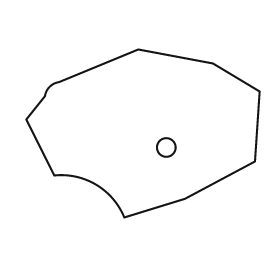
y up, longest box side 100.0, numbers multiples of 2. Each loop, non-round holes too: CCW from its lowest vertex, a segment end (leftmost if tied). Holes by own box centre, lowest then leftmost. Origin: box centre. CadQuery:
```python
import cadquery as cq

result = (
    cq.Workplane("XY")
    .moveTo(-8.0, -36.0)
    .lineTo(18.0, -28.0)
    .lineTo(48.0, -12.0)
    .lineTo(50.0, 18.0)
    .lineTo(30.0, 30.0)
    .lineTo(-2.0, 36.0)
    .lineTo(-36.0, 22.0)
    .threePointArc((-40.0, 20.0), (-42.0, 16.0))
    .lineTo(-50.0, 6.0)
    .lineTo(-38.0, -18.0)
    .threePointArc((-20.0, -22.0), (-8.0, -36.0))
    .close()
    .moveTo(10.0, -6.0)
    .circle(4.0)
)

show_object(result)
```